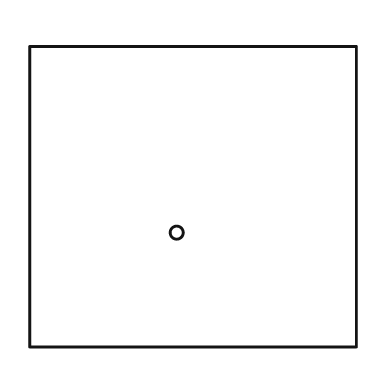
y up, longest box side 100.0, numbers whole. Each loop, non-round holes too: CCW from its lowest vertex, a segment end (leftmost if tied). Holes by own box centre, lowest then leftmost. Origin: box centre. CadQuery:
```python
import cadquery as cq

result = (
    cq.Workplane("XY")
    .moveTo(-50.0, -46.0)
    .lineTo(50.0, -46.0)
    .lineTo(50.0, 46.0)
    .lineTo(-50.0, 46.0)
    .close()
    .moveTo(-5.0, -11.0)
    .circle(2.0)
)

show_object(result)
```